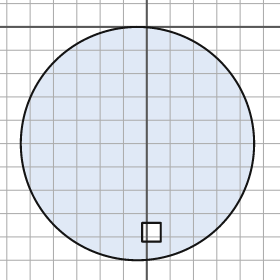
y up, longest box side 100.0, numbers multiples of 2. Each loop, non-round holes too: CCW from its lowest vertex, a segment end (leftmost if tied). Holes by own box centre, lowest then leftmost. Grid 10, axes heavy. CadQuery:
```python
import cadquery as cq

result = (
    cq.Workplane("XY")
    .moveTo(-4.0, -50.0)
    .circle(50.0)
    .moveTo(-2.0, -92.0)
    .lineTo(6.0, -92.0)
    .lineTo(6.0, -84.0)
    .lineTo(-2.0, -84.0)
    .close()
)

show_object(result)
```